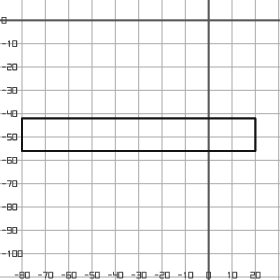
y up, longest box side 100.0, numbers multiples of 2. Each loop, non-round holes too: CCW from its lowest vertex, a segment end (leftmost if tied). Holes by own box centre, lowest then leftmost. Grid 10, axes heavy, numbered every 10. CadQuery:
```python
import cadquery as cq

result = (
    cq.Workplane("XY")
    .moveTo(-80.0, -56.0)
    .lineTo(20.0, -56.0)
    .lineTo(20.0, -42.0)
    .lineTo(-80.0, -42.0)
    .close()
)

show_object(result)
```